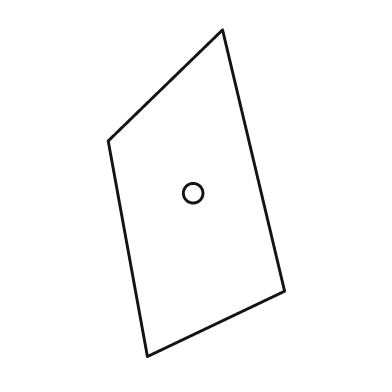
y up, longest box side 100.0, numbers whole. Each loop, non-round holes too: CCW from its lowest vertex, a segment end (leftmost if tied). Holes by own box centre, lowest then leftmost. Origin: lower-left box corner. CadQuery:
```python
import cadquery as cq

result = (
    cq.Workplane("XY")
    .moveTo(12.0, 0.0)
    .lineTo(54.0, 20.0)
    .lineTo(35.0, 100.0)
    .lineTo(0.0, 66.0)
    .close()
    .moveTo(26.0, 50.0)
    .circle(3.0)
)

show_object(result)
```